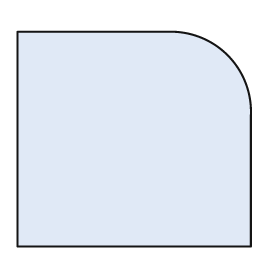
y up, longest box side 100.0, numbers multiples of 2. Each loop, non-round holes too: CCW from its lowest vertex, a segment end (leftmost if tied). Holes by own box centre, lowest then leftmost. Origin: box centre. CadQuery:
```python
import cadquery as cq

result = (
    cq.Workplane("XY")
    .moveTo(-50.0, -46.0)
    .lineTo(50.0, -46.0)
    .lineTo(50.0, 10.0)
    .threePointArc((40.0, 36.0), (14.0, 46.0))
    .lineTo(-50.0, 46.0)
    .close()
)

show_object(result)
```